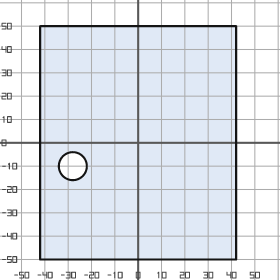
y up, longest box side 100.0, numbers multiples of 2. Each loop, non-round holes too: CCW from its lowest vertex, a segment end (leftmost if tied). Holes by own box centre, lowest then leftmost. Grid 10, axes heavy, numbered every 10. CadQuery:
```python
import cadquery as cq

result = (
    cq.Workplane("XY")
    .moveTo(-42.0, -50.0)
    .lineTo(42.0, -50.0)
    .lineTo(42.0, 50.0)
    .lineTo(-42.0, 50.0)
    .close()
    .moveTo(-28.0, -10.0)
    .circle(6.0)
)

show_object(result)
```